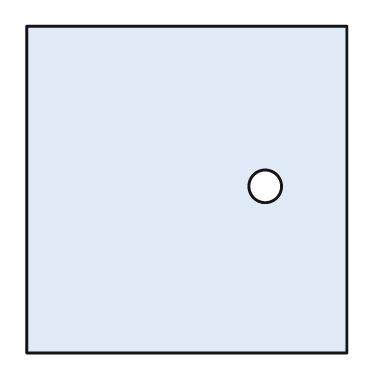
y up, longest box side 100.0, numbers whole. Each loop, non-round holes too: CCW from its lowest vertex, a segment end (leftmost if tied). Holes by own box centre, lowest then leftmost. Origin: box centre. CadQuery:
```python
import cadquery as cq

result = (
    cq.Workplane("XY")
    .moveTo(-49.0, -50.0)
    .lineTo(49.0, -50.0)
    .lineTo(49.0, 50.0)
    .lineTo(-49.0, 50.0)
    .close()
    .moveTo(24.0, 1.0)
    .circle(5.0)
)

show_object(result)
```